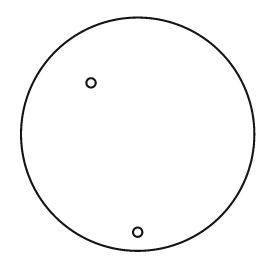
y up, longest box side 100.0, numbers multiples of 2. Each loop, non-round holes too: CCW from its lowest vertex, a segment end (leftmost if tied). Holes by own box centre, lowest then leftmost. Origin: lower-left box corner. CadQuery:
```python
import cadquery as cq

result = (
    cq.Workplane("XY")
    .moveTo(50.0, 50.0)
    .circle(50.0)
    .moveTo(50.0, 8.0)
    .circle(2.0)
    .moveTo(30.0, 72.0)
    .circle(2.0)
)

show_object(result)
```